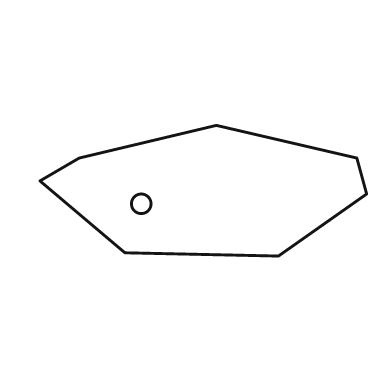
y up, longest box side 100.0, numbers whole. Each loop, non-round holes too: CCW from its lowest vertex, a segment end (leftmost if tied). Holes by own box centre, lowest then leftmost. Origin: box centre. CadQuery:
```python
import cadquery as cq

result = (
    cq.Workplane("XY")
    .moveTo(23.0, -20.0)
    .lineTo(50.0, -1.0)
    .lineTo(47.0, 10.0)
    .lineTo(4.0, 20.0)
    .lineTo(-38.0, 10.0)
    .lineTo(-50.0, 3.0)
    .lineTo(-24.0, -19.0)
    .close()
    .moveTo(-19.0, -4.0)
    .circle(3.0)
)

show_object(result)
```